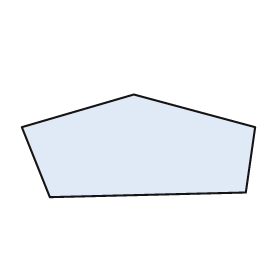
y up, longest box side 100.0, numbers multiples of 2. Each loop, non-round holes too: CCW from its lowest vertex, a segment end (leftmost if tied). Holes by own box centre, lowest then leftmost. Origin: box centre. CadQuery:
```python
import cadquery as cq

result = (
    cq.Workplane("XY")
    .moveTo(-38.0, -22.0)
    .lineTo(46.0, -20.0)
    .lineTo(50.0, 8.0)
    .lineTo(-2.0, 22.0)
    .lineTo(-50.0, 8.0)
    .close()
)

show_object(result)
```